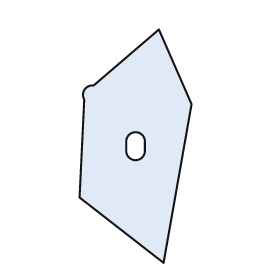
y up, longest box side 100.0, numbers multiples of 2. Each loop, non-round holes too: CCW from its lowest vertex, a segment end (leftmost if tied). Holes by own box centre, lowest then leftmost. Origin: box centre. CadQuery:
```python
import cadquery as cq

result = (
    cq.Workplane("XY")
    .moveTo(12.0, -50.0)
    .lineTo(24.0, 18.0)
    .lineTo(10.0, 50.0)
    .lineTo(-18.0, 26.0)
    .threePointArc((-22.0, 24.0), (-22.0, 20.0))
    .lineTo(-24.0, -22.0)
    .close()
    .moveTo(-4.0, -2.0)
    .threePointArc((0.0, -6.0), (4.0, -2.0))
    .lineTo(4.0, 2.0)
    .threePointArc((0.0, 6.0), (-4.0, 2.0))
    .close()
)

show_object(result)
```